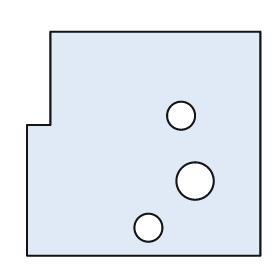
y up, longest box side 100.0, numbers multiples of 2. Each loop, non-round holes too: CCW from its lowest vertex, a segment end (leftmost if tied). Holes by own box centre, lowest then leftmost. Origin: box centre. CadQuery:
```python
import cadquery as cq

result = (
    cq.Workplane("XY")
    .moveTo(-50.0, -48.0)
    .lineTo(50.0, -48.0)
    .lineTo(50.0, 48.0)
    .lineTo(-40.0, 48.0)
    .lineTo(-40.0, 8.0)
    .lineTo(-50.0, 8.0)
    .close()
    .moveTo(2.0, -36.0)
    .circle(6.0)
    .moveTo(22.0, -16.0)
    .circle(8.0)
    .moveTo(16.0, 12.0)
    .circle(6.0)
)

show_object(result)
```